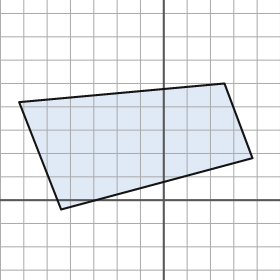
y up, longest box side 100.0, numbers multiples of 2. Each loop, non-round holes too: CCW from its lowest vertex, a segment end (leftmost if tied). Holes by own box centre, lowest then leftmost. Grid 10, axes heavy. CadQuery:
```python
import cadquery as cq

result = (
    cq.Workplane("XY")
    .moveTo(-44.0, -4.0)
    .lineTo(38.0, 18.0)
    .lineTo(26.0, 50.0)
    .lineTo(-62.0, 42.0)
    .close()
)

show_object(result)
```